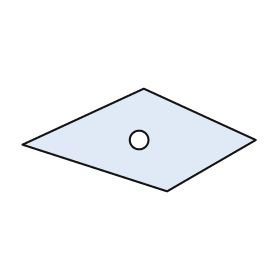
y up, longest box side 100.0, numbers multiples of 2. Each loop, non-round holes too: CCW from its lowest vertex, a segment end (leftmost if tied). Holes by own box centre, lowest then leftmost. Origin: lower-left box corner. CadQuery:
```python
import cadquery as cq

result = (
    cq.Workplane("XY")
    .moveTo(62.0, 0.0)
    .lineTo(100.0, 22.0)
    .lineTo(52.0, 44.0)
    .lineTo(0.0, 20.0)
    .close()
    .moveTo(50.0, 22.0)
    .circle(4.0)
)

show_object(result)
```